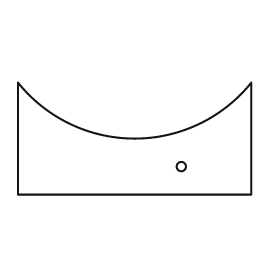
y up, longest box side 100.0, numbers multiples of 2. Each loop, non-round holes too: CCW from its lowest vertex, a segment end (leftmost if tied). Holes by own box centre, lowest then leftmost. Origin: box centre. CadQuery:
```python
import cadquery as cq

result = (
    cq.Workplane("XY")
    .moveTo(-50.0, -24.0)
    .lineTo(50.0, -24.0)
    .lineTo(50.0, 24.0)
    .threePointArc((0.0, 0.0), (-50.0, 24.0))
    .close()
    .moveTo(20.0, -12.0)
    .circle(2.0)
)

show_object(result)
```